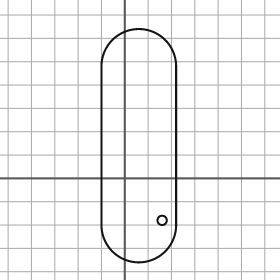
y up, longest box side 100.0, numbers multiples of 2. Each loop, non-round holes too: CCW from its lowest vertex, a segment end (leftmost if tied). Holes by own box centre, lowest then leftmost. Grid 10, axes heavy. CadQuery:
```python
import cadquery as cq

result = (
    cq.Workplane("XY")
    .moveTo(-10.0, -20.0)
    .threePointArc((6.0, -36.0), (22.0, -20.0))
    .lineTo(22.0, 48.0)
    .threePointArc((6.0, 64.0), (-10.0, 48.0))
    .close()
    .moveTo(16.0, -18.0)
    .circle(2.0)
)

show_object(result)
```